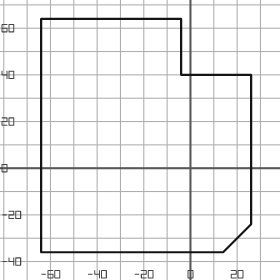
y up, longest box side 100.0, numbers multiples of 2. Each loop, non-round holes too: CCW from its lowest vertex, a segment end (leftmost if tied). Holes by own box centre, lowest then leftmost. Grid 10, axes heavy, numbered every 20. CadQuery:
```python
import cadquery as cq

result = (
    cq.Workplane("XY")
    .moveTo(-64.0, -36.0)
    .lineTo(14.0, -36.0)
    .lineTo(26.0, -24.0)
    .lineTo(26.0, 40.0)
    .lineTo(-4.0, 40.0)
    .lineTo(-4.0, 64.0)
    .lineTo(-64.0, 64.0)
    .close()
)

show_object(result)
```